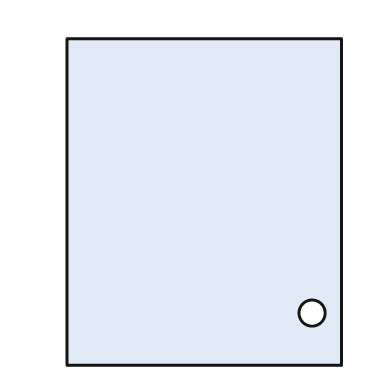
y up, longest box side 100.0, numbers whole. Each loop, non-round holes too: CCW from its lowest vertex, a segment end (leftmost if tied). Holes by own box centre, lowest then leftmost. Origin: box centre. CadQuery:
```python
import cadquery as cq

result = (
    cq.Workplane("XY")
    .moveTo(-42.0, -50.0)
    .lineTo(42.0, -50.0)
    .lineTo(42.0, 50.0)
    .lineTo(-42.0, 50.0)
    .close()
    .moveTo(33.0, -34.0)
    .circle(4.0)
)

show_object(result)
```